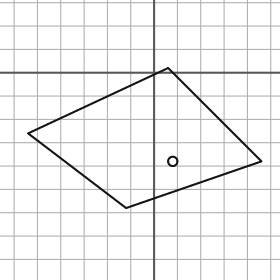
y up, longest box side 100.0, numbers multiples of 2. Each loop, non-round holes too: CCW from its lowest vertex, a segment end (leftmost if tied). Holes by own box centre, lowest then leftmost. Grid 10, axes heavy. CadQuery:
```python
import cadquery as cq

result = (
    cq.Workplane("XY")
    .moveTo(-12.0, -58.0)
    .lineTo(46.0, -38.0)
    .lineTo(6.0, 2.0)
    .lineTo(-54.0, -26.0)
    .close()
    .moveTo(8.0, -38.0)
    .circle(2.0)
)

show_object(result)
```